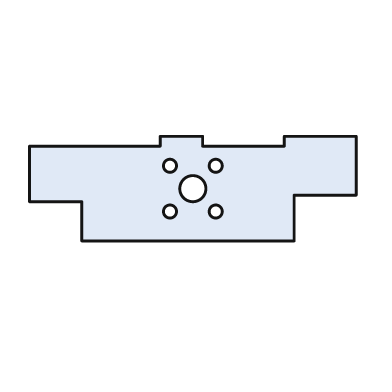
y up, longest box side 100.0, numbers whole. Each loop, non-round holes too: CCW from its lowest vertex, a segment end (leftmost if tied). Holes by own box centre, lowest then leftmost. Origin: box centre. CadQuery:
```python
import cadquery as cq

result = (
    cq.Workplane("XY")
    .moveTo(-34.0, -16.0)
    .lineTo(31.0, -16.0)
    .lineTo(31.0, -2.0)
    .lineTo(50.0, -2.0)
    .lineTo(50.0, 16.0)
    .lineTo(28.0, 16.0)
    .lineTo(28.0, 13.0)
    .lineTo(3.0, 13.0)
    .lineTo(3.0, 16.0)
    .lineTo(-10.0, 16.0)
    .lineTo(-10.0, 13.0)
    .lineTo(-50.0, 13.0)
    .lineTo(-50.0, -4.0)
    .lineTo(-34.0, -4.0)
    .close()
    .moveTo(-7.0, -7.0)
    .circle(2.0)
    .moveTo(7.0, -7.0)
    .circle(2.0)
    .moveTo(0.0, 0.0)
    .circle(4.0)
    .moveTo(-7.0, 7.0)
    .circle(2.0)
    .moveTo(7.0, 7.0)
    .circle(2.0)
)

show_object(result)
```